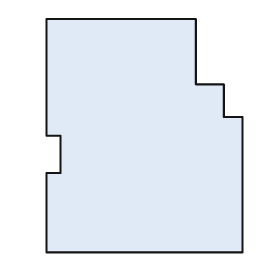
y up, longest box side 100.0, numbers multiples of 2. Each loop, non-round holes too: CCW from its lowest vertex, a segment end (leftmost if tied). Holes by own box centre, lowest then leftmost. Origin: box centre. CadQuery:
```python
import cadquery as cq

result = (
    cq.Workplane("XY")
    .moveTo(-42.0, -50.0)
    .lineTo(42.0, -50.0)
    .lineTo(42.0, 8.0)
    .lineTo(34.0, 8.0)
    .lineTo(34.0, 22.0)
    .lineTo(22.0, 22.0)
    .lineTo(22.0, 50.0)
    .lineTo(-42.0, 50.0)
    .lineTo(-42.0, 0.0)
    .lineTo(-36.0, 0.0)
    .lineTo(-36.0, -16.0)
    .lineTo(-42.0, -16.0)
    .close()
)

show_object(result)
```